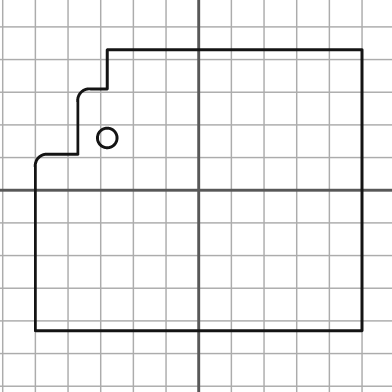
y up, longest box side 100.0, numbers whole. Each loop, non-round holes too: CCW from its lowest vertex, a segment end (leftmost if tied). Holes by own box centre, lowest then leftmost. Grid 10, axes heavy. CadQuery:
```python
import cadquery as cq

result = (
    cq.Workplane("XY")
    .moveTo(-50.0, -43.0)
    .lineTo(50.0, -43.0)
    .lineTo(50.0, 43.0)
    .lineTo(-28.0, 43.0)
    .lineTo(-28.0, 31.0)
    .lineTo(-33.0, 31.0)
    .threePointArc((-36.0, 30.0), (-37.0, 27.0))
    .lineTo(-37.0, 11.0)
    .lineTo(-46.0, 11.0)
    .threePointArc((-49.0, 10.0), (-50.0, 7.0))
    .close()
    .moveTo(-28.0, 16.0)
    .circle(3.0)
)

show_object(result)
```